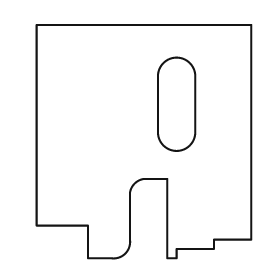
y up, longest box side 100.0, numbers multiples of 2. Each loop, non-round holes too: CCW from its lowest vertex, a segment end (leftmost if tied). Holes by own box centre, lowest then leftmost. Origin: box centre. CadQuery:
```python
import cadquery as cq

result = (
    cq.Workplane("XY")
    .moveTo(-24.0, -50.0)
    .lineTo(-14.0, -50.0)
    .threePointArc((-8.0, -48.0), (-6.0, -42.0))
    .lineTo(-6.0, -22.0)
    .threePointArc((-4.0, -18.0), (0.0, -16.0))
    .lineTo(10.0, -16.0)
    .lineTo(10.0, -50.0)
    .lineTo(14.0, -50.0)
    .lineTo(14.0, -46.0)
    .lineTo(30.0, -46.0)
    .lineTo(30.0, -42.0)
    .lineTo(46.0, -42.0)
    .lineTo(46.0, 50.0)
    .lineTo(-46.0, 50.0)
    .lineTo(-46.0, -36.0)
    .lineTo(-24.0, -36.0)
    .close()
    .moveTo(6.0, 4.0)
    .threePointArc((14.0, -4.0), (22.0, 4.0))
    .lineTo(22.0, 28.0)
    .threePointArc((14.0, 36.0), (6.0, 28.0))
    .close()
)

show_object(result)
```